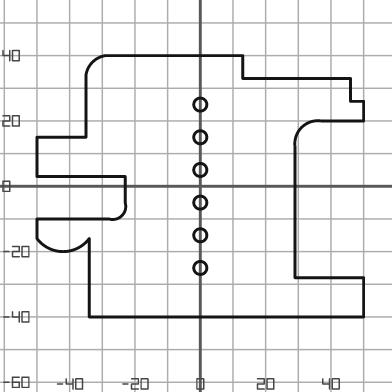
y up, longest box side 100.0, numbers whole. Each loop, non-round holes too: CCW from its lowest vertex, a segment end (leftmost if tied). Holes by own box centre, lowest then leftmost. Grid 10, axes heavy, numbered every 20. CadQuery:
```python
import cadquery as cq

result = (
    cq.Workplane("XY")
    .moveTo(-34.0, -40.0)
    .lineTo(50.0, -40.0)
    .lineTo(50.0, -28.0)
    .lineTo(29.0, -28.0)
    .lineTo(29.0, 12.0)
    .threePointArc((31.0, 18.0), (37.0, 20.0))
    .lineTo(50.0, 20.0)
    .lineTo(50.0, 26.0)
    .lineTo(46.0, 26.0)
    .lineTo(46.0, 33.0)
    .lineTo(13.0, 33.0)
    .lineTo(13.0, 40.0)
    .lineTo(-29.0, 40.0)
    .threePointArc((-33.0, 38.0), (-35.0, 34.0))
    .lineTo(-35.0, 15.0)
    .lineTo(-50.0, 15.0)
    .lineTo(-50.0, 3.0)
    .lineTo(-23.0, 3.0)
    .lineTo(-23.0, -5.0)
    .threePointArc((-24.0, -9.0), (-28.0, -10.0))
    .lineTo(-50.0, -10.0)
    .lineTo(-50.0, -16.0)
    .threePointArc((-42.0, -20.0), (-34.0, -16.0))
    .close()
    .moveTo(0.0, -25.0)
    .circle(2.0)
    .moveTo(0.0, -15.0)
    .circle(2.0)
    .moveTo(0.0, -5.0)
    .circle(2.0)
    .moveTo(0.0, 5.0)
    .circle(2.0)
    .moveTo(0.0, 15.0)
    .circle(2.0)
    .moveTo(0.0, 25.0)
    .circle(2.0)
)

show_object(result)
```